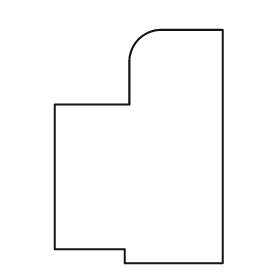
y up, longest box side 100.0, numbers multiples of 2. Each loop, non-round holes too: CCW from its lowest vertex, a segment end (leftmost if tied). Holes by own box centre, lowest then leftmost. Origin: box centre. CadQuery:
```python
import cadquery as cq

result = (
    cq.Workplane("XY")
    .moveTo(-6.0, -50.0)
    .lineTo(36.0, -50.0)
    .lineTo(36.0, 50.0)
    .lineTo(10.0, 50.0)
    .threePointArc((0.0, 46.0), (-4.0, 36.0))
    .lineTo(-4.0, 18.0)
    .lineTo(-36.0, 18.0)
    .lineTo(-36.0, -44.0)
    .lineTo(-6.0, -44.0)
    .close()
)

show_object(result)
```